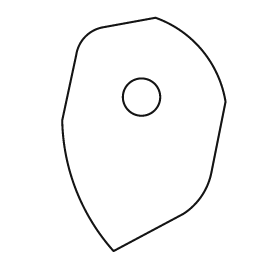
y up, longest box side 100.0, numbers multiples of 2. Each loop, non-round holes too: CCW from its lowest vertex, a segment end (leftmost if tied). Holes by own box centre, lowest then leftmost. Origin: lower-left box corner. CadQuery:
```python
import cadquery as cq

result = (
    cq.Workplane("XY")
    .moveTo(22.0, 0.0)
    .lineTo(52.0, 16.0)
    .threePointArc((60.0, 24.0), (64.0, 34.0))
    .lineTo(70.0, 64.0)
    .threePointArc((60.0, 86.0), (40.0, 100.0))
    .lineTo(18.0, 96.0)
    .threePointArc((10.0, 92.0), (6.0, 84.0))
    .lineTo(0.0, 56.0)
    .threePointArc((6.0, 26.0), (22.0, 0.0))
    .close()
    .moveTo(34.0, 66.0)
    .circle(8.0)
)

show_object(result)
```